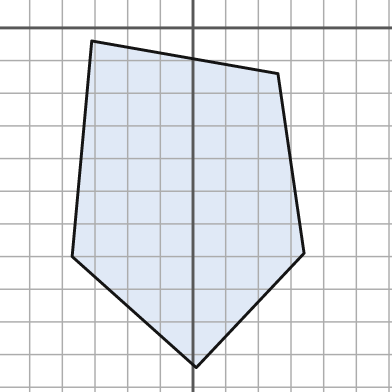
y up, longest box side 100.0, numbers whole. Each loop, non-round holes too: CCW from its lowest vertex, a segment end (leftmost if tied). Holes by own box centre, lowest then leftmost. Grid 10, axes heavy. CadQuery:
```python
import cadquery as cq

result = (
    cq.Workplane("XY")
    .moveTo(1.0, -104.0)
    .lineTo(34.0, -69.0)
    .lineTo(26.0, -14.0)
    .lineTo(-31.0, -4.0)
    .lineTo(-37.0, -70.0)
    .close()
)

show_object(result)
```